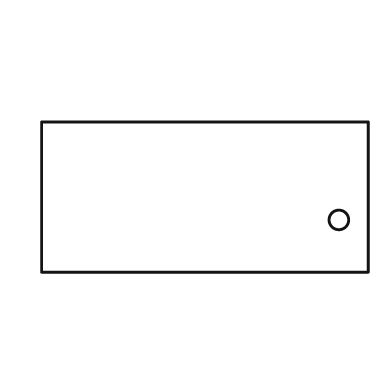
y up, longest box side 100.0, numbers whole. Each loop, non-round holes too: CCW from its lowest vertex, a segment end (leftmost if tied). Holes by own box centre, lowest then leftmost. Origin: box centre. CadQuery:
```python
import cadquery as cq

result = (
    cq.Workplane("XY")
    .moveTo(-50.0, -23.0)
    .lineTo(50.0, -23.0)
    .lineTo(50.0, 23.0)
    .lineTo(-50.0, 23.0)
    .close()
    .moveTo(41.0, -7.0)
    .circle(3.0)
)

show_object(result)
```